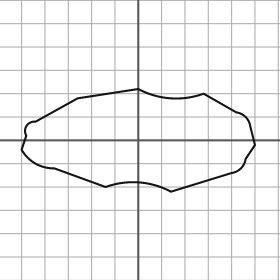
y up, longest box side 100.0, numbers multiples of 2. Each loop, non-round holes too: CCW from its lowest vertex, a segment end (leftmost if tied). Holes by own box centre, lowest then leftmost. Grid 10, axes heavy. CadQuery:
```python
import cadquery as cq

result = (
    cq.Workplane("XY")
    .moveTo(14.0, -22.0)
    .lineTo(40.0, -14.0)
    .threePointArc((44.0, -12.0), (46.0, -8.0))
    .lineTo(50.0, -2.0)
    .lineTo(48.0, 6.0)
    .threePointArc((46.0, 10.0), (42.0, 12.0))
    .lineTo(28.0, 20.0)
    .threePointArc((14.0, 18.0), (0.0, 22.0))
    .lineTo(-26.0, 18.0)
    .lineTo(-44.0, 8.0)
    .threePointArc((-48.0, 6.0), (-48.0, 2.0))
    .lineTo(-50.0, -4.0)
    .threePointArc((-44.0, -10.0), (-36.0, -12.0))
    .lineTo(-14.0, -20.0)
    .threePointArc((0.0, -18.0), (14.0, -22.0))
    .close()
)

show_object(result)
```